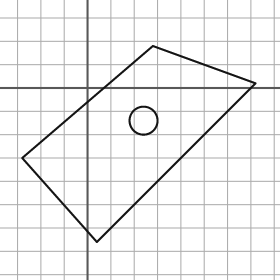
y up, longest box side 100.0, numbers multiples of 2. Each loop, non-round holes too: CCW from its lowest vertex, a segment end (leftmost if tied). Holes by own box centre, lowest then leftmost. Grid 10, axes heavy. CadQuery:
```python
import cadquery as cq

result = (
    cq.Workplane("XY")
    .moveTo(4.0, -66.0)
    .lineTo(72.0, 2.0)
    .lineTo(28.0, 18.0)
    .lineTo(-28.0, -30.0)
    .close()
    .moveTo(24.0, -14.0)
    .circle(6.0)
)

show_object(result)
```